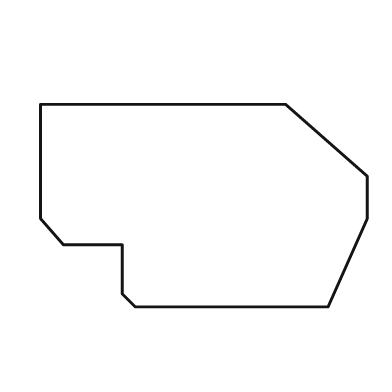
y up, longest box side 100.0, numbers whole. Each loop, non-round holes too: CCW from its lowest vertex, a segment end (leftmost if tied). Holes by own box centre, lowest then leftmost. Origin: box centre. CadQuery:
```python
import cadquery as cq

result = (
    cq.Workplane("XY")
    .moveTo(-21.0, -31.0)
    .lineTo(38.0, -31.0)
    .lineTo(50.0, -4.0)
    .lineTo(50.0, 9.0)
    .lineTo(25.0, 31.0)
    .lineTo(-50.0, 31.0)
    .lineTo(-50.0, -4.0)
    .lineTo(-43.0, -12.0)
    .lineTo(-25.0, -12.0)
    .lineTo(-25.0, -27.0)
    .close()
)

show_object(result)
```